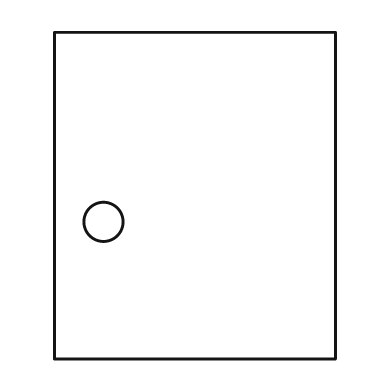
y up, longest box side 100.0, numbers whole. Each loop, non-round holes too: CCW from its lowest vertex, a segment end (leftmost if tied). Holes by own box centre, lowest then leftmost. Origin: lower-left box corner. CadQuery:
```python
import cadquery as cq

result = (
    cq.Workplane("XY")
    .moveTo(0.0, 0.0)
    .lineTo(86.0, 0.0)
    .lineTo(86.0, 100.0)
    .lineTo(0.0, 100.0)
    .close()
    .moveTo(15.0, 42.0)
    .circle(6.0)
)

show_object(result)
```